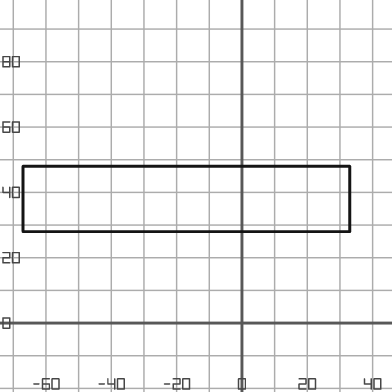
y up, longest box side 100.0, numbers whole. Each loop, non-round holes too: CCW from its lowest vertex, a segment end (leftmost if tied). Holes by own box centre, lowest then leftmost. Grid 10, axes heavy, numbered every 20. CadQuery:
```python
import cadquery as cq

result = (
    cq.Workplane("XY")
    .moveTo(-67.0, 28.0)
    .lineTo(33.0, 28.0)
    .lineTo(33.0, 48.0)
    .lineTo(-67.0, 48.0)
    .close()
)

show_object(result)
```